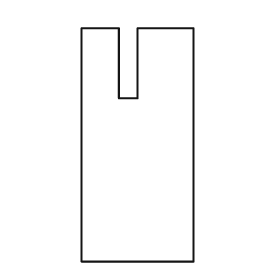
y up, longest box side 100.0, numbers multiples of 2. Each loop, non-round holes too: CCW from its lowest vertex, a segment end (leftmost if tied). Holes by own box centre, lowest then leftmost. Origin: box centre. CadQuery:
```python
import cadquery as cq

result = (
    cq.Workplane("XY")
    .moveTo(-24.0, -50.0)
    .lineTo(24.0, -50.0)
    .lineTo(24.0, 50.0)
    .lineTo(0.0, 50.0)
    .lineTo(0.0, 20.0)
    .lineTo(-8.0, 20.0)
    .lineTo(-8.0, 50.0)
    .lineTo(-24.0, 50.0)
    .close()
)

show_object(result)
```